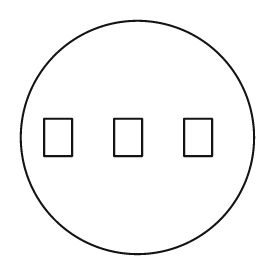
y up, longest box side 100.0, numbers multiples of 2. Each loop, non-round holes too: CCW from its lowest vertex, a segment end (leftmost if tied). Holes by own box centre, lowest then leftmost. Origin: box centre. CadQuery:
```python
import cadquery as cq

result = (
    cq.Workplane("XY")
    .moveTo(0.0, 0.0)
    .circle(50.0)
    .moveTo(-40.0, -8.0)
    .lineTo(-28.0, -8.0)
    .lineTo(-28.0, 8.0)
    .lineTo(-40.0, 8.0)
    .close()
    .moveTo(-10.0, -8.0)
    .lineTo(2.0, -8.0)
    .lineTo(2.0, 8.0)
    .lineTo(-10.0, 8.0)
    .close()
    .moveTo(20.0, -8.0)
    .lineTo(32.0, -8.0)
    .lineTo(32.0, 8.0)
    .lineTo(20.0, 8.0)
    .close()
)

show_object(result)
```